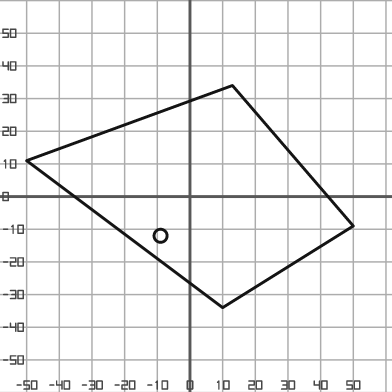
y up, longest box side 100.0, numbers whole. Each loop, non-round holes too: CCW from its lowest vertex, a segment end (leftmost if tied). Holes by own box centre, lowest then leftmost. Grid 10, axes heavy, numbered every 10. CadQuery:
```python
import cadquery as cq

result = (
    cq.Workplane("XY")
    .moveTo(10.0, -34.0)
    .lineTo(50.0, -9.0)
    .lineTo(13.0, 34.0)
    .lineTo(-50.0, 11.0)
    .close()
    .moveTo(-9.0, -12.0)
    .circle(2.0)
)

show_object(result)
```